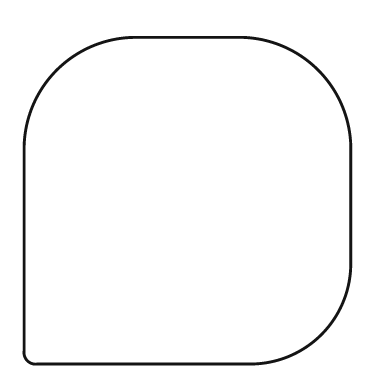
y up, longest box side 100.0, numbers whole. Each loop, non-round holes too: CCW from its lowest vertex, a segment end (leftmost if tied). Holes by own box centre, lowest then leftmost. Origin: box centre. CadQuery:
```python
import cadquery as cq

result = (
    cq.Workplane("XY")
    .moveTo(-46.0, -50.0)
    .lineTo(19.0, -50.0)
    .threePointArc((41.0, -41.0), (50.0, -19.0))
    .lineTo(50.0, 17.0)
    .threePointArc((40.0, 40.0), (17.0, 50.0))
    .lineTo(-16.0, 50.0)
    .threePointArc((-40.0, 40.0), (-50.0, 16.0))
    .lineTo(-50.0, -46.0)
    .threePointArc((-49.0, -49.0), (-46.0, -50.0))
    .close()
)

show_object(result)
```